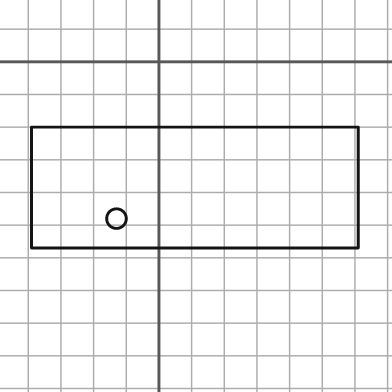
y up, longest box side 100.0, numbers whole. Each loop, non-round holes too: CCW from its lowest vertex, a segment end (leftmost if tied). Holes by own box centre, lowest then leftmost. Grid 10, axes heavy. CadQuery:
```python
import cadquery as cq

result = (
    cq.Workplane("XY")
    .moveTo(-39.0, -57.0)
    .lineTo(61.0, -57.0)
    .lineTo(61.0, -20.0)
    .lineTo(-39.0, -20.0)
    .close()
    .moveTo(-13.0, -48.0)
    .circle(3.0)
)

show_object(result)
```